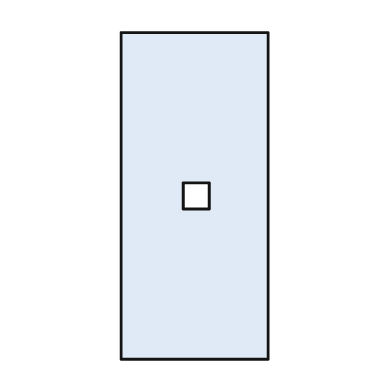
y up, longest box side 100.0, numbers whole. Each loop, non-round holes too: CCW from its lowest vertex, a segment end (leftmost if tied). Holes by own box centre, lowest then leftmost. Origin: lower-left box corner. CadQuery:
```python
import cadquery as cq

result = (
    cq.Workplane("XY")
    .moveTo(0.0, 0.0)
    .lineTo(45.0, 0.0)
    .lineTo(45.0, 100.0)
    .lineTo(0.0, 100.0)
    .close()
    .moveTo(19.0, 46.0)
    .lineTo(27.0, 46.0)
    .lineTo(27.0, 54.0)
    .lineTo(19.0, 54.0)
    .close()
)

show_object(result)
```